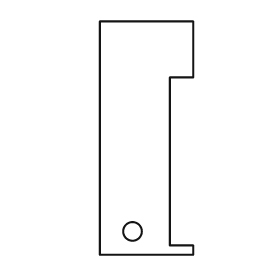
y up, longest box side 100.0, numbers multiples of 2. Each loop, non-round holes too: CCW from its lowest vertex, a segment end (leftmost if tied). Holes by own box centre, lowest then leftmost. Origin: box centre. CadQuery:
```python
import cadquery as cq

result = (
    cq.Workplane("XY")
    .moveTo(-20.0, -50.0)
    .lineTo(20.0, -50.0)
    .lineTo(20.0, -46.0)
    .lineTo(10.0, -46.0)
    .lineTo(10.0, 26.0)
    .lineTo(20.0, 26.0)
    .lineTo(20.0, 50.0)
    .lineTo(-20.0, 50.0)
    .close()
    .moveTo(-6.0, -40.0)
    .circle(4.0)
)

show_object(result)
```